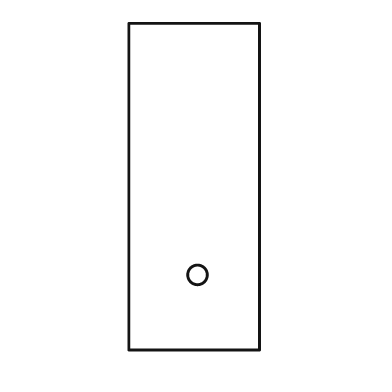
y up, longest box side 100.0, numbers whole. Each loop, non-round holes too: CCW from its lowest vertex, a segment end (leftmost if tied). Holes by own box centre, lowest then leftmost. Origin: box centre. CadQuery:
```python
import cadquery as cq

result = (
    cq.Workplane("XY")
    .moveTo(-20.0, -50.0)
    .lineTo(20.0, -50.0)
    .lineTo(20.0, 50.0)
    .lineTo(-20.0, 50.0)
    .close()
    .moveTo(1.0, -27.0)
    .circle(3.0)
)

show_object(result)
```